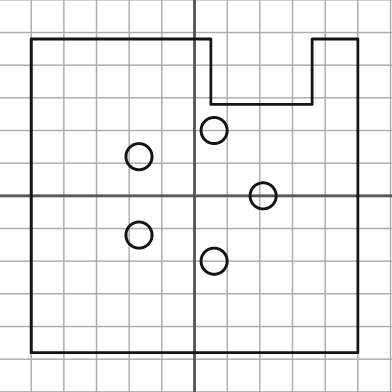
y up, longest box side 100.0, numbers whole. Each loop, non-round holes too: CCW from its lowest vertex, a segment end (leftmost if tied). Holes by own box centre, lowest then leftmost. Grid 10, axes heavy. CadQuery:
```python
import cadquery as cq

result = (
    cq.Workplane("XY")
    .moveTo(-50.0, -48.0)
    .lineTo(50.0, -48.0)
    .lineTo(50.0, 48.0)
    .lineTo(36.0, 48.0)
    .lineTo(36.0, 28.0)
    .lineTo(5.0, 28.0)
    .lineTo(5.0, 48.0)
    .lineTo(-50.0, 48.0)
    .close()
    .moveTo(6.0, -20.0)
    .circle(4.0)
    .moveTo(-17.0, -12.0)
    .circle(4.0)
    .moveTo(21.0, 0.0)
    .circle(4.0)
    .moveTo(-17.0, 12.0)
    .circle(4.0)
    .moveTo(6.0, 20.0)
    .circle(4.0)
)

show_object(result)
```